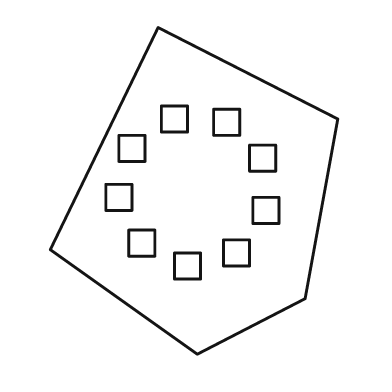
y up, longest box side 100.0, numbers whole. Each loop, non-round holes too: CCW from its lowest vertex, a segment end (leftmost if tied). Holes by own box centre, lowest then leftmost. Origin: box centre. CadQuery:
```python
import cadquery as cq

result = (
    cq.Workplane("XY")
    .moveTo(1.0, -50.0)
    .lineTo(34.0, -33.0)
    .lineTo(44.0, 22.0)
    .lineTo(-11.0, 50.0)
    .lineTo(-44.0, -18.0)
    .close()
    .moveTo(-6.0, -27.0)
    .lineTo(2.0, -27.0)
    .lineTo(2.0, -19.0)
    .lineTo(-6.0, -19.0)
    .close()
    .moveTo(9.0, -23.0)
    .lineTo(17.0, -23.0)
    .lineTo(17.0, -15.0)
    .lineTo(9.0, -15.0)
    .close()
    .moveTo(-20.0, -20.0)
    .lineTo(-12.0, -20.0)
    .lineTo(-12.0, -12.0)
    .lineTo(-20.0, -12.0)
    .close()
    .moveTo(18.0, -10.0)
    .lineTo(26.0, -10.0)
    .lineTo(26.0, -2.0)
    .lineTo(18.0, -2.0)
    .close()
    .moveTo(-27.0, -6.0)
    .lineTo(-19.0, -6.0)
    .lineTo(-19.0, 2.0)
    .lineTo(-27.0, 2.0)
    .close()
    .moveTo(17.0, 6.0)
    .lineTo(25.0, 6.0)
    .lineTo(25.0, 14.0)
    .lineTo(17.0, 14.0)
    .close()
    .moveTo(-23.0, 9.0)
    .lineTo(-15.0, 9.0)
    .lineTo(-15.0, 17.0)
    .lineTo(-23.0, 17.0)
    .close()
    .moveTo(6.0, 17.0)
    .lineTo(14.0, 17.0)
    .lineTo(14.0, 25.0)
    .lineTo(6.0, 25.0)
    .close()
    .moveTo(-10.0, 18.0)
    .lineTo(-2.0, 18.0)
    .lineTo(-2.0, 26.0)
    .lineTo(-10.0, 26.0)
    .close()
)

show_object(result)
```